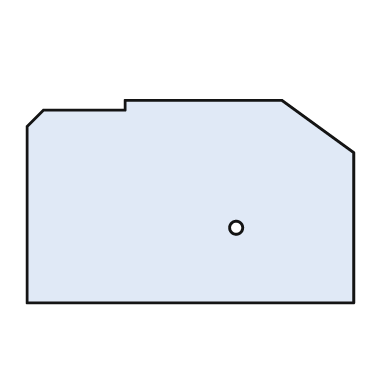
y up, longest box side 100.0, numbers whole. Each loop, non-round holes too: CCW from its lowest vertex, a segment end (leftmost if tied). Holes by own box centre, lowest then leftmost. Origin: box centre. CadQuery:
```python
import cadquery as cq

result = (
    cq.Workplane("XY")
    .moveTo(-50.0, -31.0)
    .lineTo(50.0, -31.0)
    .lineTo(50.0, 15.0)
    .lineTo(28.0, 31.0)
    .lineTo(-20.0, 31.0)
    .lineTo(-20.0, 28.0)
    .lineTo(-45.0, 28.0)
    .lineTo(-50.0, 23.0)
    .close()
    .moveTo(14.0, -8.0)
    .circle(2.0)
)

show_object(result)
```